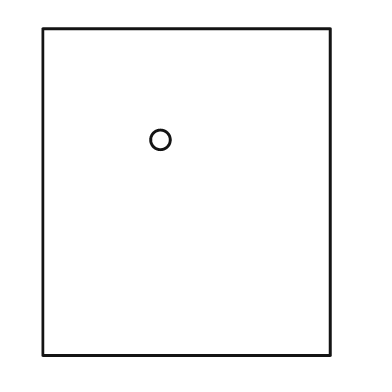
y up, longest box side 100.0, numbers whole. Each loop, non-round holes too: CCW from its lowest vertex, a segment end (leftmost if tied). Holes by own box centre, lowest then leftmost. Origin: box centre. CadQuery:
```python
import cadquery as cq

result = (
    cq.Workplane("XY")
    .moveTo(-44.0, -50.0)
    .lineTo(44.0, -50.0)
    .lineTo(44.0, 50.0)
    .lineTo(-44.0, 50.0)
    .close()
    .moveTo(-8.0, 16.0)
    .circle(3.0)
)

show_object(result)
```